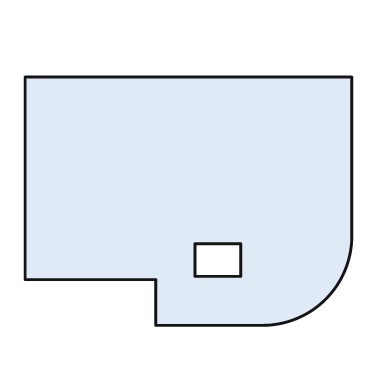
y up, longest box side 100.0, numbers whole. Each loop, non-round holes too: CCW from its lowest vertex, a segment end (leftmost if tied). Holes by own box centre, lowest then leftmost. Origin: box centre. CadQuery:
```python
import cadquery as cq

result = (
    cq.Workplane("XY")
    .moveTo(-10.0, -38.0)
    .lineTo(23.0, -38.0)
    .threePointArc((42.0, -30.0), (50.0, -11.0))
    .lineTo(50.0, 38.0)
    .lineTo(-50.0, 38.0)
    .lineTo(-50.0, -24.0)
    .lineTo(-10.0, -24.0)
    .close()
    .moveTo(2.0, -23.0)
    .lineTo(16.0, -23.0)
    .lineTo(16.0, -13.0)
    .lineTo(2.0, -13.0)
    .close()
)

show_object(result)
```